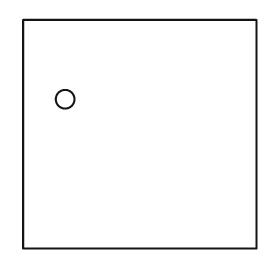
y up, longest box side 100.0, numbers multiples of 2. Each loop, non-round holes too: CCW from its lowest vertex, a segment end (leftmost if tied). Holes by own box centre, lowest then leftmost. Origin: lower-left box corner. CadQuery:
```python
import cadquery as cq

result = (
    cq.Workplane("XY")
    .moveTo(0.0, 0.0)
    .lineTo(100.0, 0.0)
    .lineTo(100.0, 98.0)
    .lineTo(0.0, 98.0)
    .close()
    .moveTo(18.0, 64.0)
    .circle(4.0)
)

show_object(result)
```